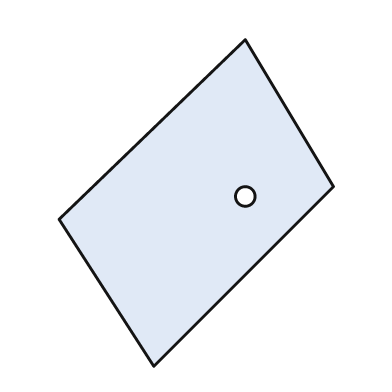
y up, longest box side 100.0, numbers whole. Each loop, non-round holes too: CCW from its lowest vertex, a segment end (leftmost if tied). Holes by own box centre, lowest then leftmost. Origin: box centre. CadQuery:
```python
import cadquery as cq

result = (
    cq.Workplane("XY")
    .moveTo(-13.0, -50.0)
    .lineTo(42.0, 5.0)
    .lineTo(15.0, 50.0)
    .lineTo(-42.0, -5.0)
    .close()
    .moveTo(15.0, 2.0)
    .circle(3.0)
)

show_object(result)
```